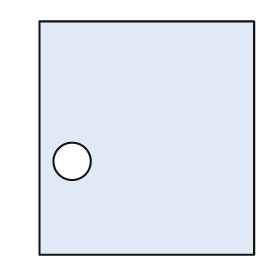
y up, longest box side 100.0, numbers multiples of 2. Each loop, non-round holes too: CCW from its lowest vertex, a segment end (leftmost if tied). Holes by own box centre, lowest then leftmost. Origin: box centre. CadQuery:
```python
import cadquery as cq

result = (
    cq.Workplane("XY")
    .moveTo(-46.0, -50.0)
    .lineTo(46.0, -50.0)
    .lineTo(46.0, 50.0)
    .lineTo(-46.0, 50.0)
    .close()
    .moveTo(-32.0, -10.0)
    .circle(8.0)
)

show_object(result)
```